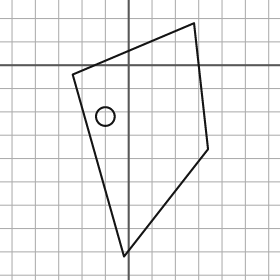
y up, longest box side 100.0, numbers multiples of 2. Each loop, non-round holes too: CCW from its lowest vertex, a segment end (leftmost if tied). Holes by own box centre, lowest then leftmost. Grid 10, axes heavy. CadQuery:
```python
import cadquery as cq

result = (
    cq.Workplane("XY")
    .moveTo(-2.0, -82.0)
    .lineTo(34.0, -36.0)
    .lineTo(28.0, 18.0)
    .lineTo(-24.0, -4.0)
    .close()
    .moveTo(-10.0, -22.0)
    .circle(4.0)
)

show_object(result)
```